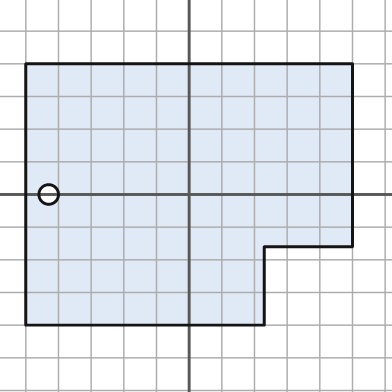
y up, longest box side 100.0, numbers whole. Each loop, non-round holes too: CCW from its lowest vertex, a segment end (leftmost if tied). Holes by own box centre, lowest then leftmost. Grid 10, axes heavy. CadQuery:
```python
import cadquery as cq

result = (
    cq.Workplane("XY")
    .moveTo(-50.0, -40.0)
    .lineTo(23.0, -40.0)
    .lineTo(23.0, -16.0)
    .lineTo(50.0, -16.0)
    .lineTo(50.0, 40.0)
    .lineTo(-50.0, 40.0)
    .close()
    .moveTo(-43.0, 0.0)
    .circle(3.0)
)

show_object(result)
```